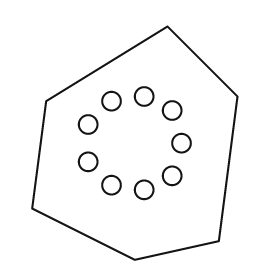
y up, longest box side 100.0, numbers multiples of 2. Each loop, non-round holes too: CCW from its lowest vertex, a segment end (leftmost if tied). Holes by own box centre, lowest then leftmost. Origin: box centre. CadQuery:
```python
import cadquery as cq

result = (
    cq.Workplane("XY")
    .moveTo(0.0, -50.0)
    .lineTo(36.0, -42.0)
    .lineTo(44.0, 20.0)
    .lineTo(14.0, 50.0)
    .lineTo(-38.0, 18.0)
    .lineTo(-44.0, -28.0)
    .close()
    .moveTo(4.0, -20.0)
    .circle(4.0)
    .moveTo(-10.0, -18.0)
    .circle(4.0)
    .moveTo(16.0, -14.0)
    .circle(4.0)
    .moveTo(-20.0, -8.0)
    .circle(4.0)
    .moveTo(20.0, 0.0)
    .circle(4.0)
    .moveTo(-20.0, 8.0)
    .circle(4.0)
    .moveTo(16.0, 14.0)
    .circle(4.0)
    .moveTo(-10.0, 18.0)
    .circle(4.0)
    .moveTo(4.0, 20.0)
    .circle(4.0)
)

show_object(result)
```